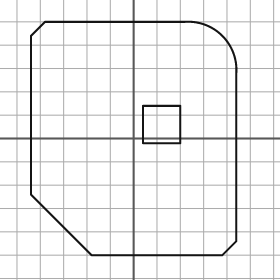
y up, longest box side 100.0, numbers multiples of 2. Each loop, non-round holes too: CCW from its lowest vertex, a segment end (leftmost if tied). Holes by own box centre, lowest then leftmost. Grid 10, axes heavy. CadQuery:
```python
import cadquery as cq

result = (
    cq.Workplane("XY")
    .moveTo(-18.0, -50.0)
    .lineTo(38.0, -50.0)
    .lineTo(44.0, -44.0)
    .lineTo(44.0, 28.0)
    .threePointArc((38.0, 44.0), (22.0, 50.0))
    .lineTo(-38.0, 50.0)
    .lineTo(-44.0, 44.0)
    .lineTo(-44.0, -24.0)
    .close()
    .moveTo(4.0, -2.0)
    .lineTo(20.0, -2.0)
    .lineTo(20.0, 14.0)
    .lineTo(4.0, 14.0)
    .close()
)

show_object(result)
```